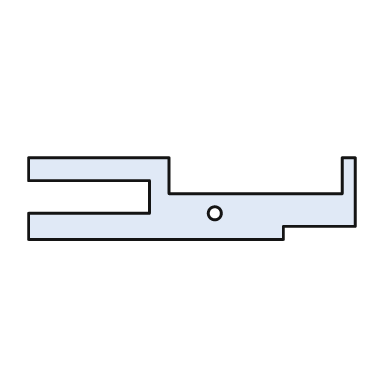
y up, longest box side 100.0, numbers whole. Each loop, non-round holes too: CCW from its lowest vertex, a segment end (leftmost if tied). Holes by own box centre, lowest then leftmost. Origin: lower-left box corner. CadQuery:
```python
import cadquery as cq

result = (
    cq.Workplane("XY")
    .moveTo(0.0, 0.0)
    .lineTo(78.0, 0.0)
    .lineTo(78.0, 4.0)
    .lineTo(100.0, 4.0)
    .lineTo(100.0, 25.0)
    .lineTo(96.0, 25.0)
    .lineTo(96.0, 14.0)
    .lineTo(43.0, 14.0)
    .lineTo(43.0, 25.0)
    .lineTo(0.0, 25.0)
    .lineTo(0.0, 18.0)
    .lineTo(37.0, 18.0)
    .lineTo(37.0, 8.0)
    .lineTo(0.0, 8.0)
    .close()
    .moveTo(57.0, 8.0)
    .circle(2.0)
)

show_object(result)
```